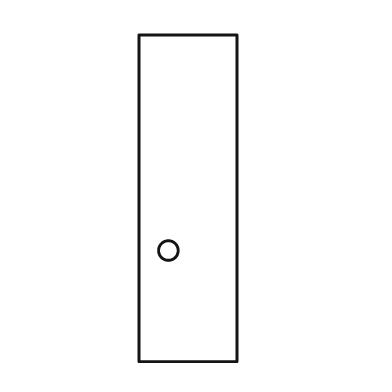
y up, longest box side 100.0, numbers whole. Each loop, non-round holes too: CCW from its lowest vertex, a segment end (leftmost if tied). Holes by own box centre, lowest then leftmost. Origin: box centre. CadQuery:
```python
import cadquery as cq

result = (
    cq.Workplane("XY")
    .moveTo(-15.0, -50.0)
    .lineTo(15.0, -50.0)
    .lineTo(15.0, 50.0)
    .lineTo(-15.0, 50.0)
    .close()
    .moveTo(-6.0, -16.0)
    .circle(3.0)
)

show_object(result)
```